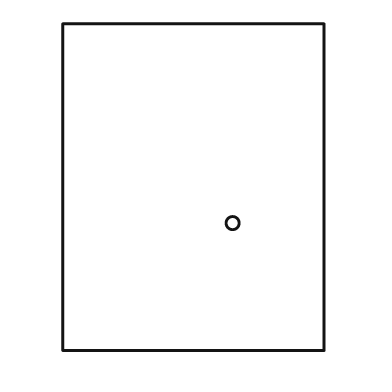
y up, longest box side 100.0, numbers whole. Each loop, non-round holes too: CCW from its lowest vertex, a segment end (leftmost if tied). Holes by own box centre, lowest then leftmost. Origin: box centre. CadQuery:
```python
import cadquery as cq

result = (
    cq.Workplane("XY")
    .moveTo(-40.0, -50.0)
    .lineTo(40.0, -50.0)
    .lineTo(40.0, 50.0)
    .lineTo(-40.0, 50.0)
    .close()
    .moveTo(12.0, -11.0)
    .circle(2.0)
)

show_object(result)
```